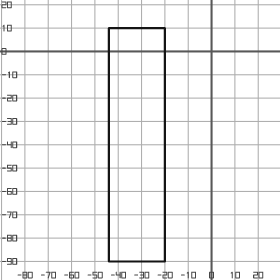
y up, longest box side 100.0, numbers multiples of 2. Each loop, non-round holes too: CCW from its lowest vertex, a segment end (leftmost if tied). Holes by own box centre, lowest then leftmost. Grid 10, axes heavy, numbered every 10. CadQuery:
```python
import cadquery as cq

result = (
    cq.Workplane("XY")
    .moveTo(-44.0, -90.0)
    .lineTo(-20.0, -90.0)
    .lineTo(-20.0, 10.0)
    .lineTo(-44.0, 10.0)
    .close()
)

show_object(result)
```